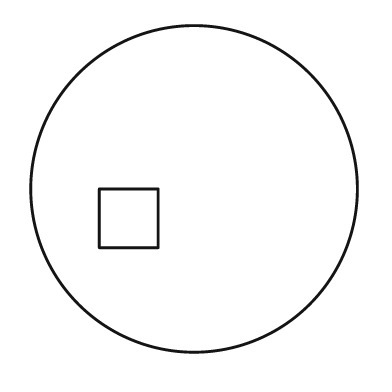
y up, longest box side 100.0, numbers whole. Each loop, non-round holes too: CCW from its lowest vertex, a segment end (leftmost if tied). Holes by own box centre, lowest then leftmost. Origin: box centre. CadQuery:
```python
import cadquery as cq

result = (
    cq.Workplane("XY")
    .moveTo(0.0, 0.0)
    .circle(50.0)
    .moveTo(-29.0, -18.0)
    .lineTo(-11.0, -18.0)
    .lineTo(-11.0, 0.0)
    .lineTo(-29.0, 0.0)
    .close()
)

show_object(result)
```